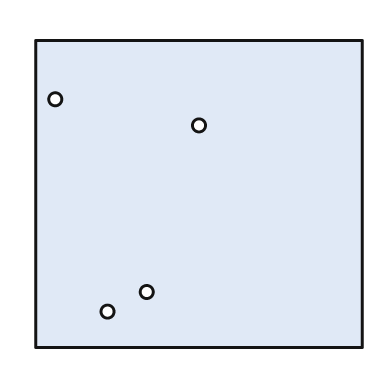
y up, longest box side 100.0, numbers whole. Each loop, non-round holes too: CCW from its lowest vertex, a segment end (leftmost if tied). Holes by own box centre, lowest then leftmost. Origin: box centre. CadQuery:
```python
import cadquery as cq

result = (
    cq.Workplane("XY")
    .moveTo(-50.0, -47.0)
    .lineTo(50.0, -47.0)
    .lineTo(50.0, 47.0)
    .lineTo(-50.0, 47.0)
    .close()
    .moveTo(-28.0, -36.0)
    .circle(2.0)
    .moveTo(-16.0, -30.0)
    .circle(2.0)
    .moveTo(0.0, 21.0)
    .circle(2.0)
    .moveTo(-44.0, 29.0)
    .circle(2.0)
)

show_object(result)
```